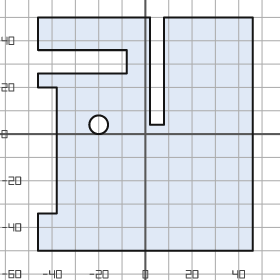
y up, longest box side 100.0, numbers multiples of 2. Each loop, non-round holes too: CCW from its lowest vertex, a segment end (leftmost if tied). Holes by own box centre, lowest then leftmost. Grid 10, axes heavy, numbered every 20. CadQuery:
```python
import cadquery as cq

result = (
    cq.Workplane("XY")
    .moveTo(-46.0, -50.0)
    .lineTo(46.0, -50.0)
    .lineTo(46.0, 50.0)
    .lineTo(8.0, 50.0)
    .lineTo(8.0, 4.0)
    .lineTo(2.0, 4.0)
    .lineTo(2.0, 50.0)
    .lineTo(-46.0, 50.0)
    .lineTo(-46.0, 36.0)
    .lineTo(-8.0, 36.0)
    .lineTo(-8.0, 26.0)
    .lineTo(-46.0, 26.0)
    .lineTo(-46.0, 20.0)
    .lineTo(-38.0, 20.0)
    .lineTo(-38.0, -34.0)
    .lineTo(-46.0, -34.0)
    .close()
    .moveTo(-20.0, 4.0)
    .circle(4.0)
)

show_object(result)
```